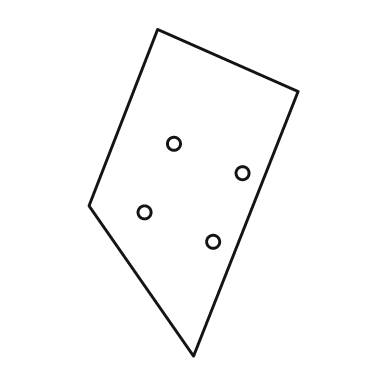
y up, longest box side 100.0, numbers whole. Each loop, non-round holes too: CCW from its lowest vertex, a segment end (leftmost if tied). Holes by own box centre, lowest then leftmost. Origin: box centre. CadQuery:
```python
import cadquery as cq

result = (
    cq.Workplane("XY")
    .moveTo(0.0, -50.0)
    .lineTo(32.0, 31.0)
    .lineTo(-11.0, 50.0)
    .lineTo(-32.0, -4.0)
    .close()
    .moveTo(6.0, -15.0)
    .circle(2.0)
    .moveTo(-15.0, -6.0)
    .circle(2.0)
    .moveTo(15.0, 6.0)
    .circle(2.0)
    .moveTo(-6.0, 15.0)
    .circle(2.0)
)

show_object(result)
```